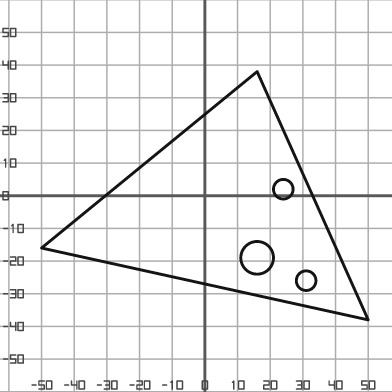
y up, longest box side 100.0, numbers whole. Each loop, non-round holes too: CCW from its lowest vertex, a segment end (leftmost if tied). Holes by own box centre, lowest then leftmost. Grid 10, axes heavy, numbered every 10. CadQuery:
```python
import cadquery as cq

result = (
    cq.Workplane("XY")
    .moveTo(50.0, -38.0)
    .lineTo(16.0, 38.0)
    .lineTo(-50.0, -16.0)
    .close()
    .moveTo(31.0, -26.0)
    .circle(3.0)
    .moveTo(16.0, -19.0)
    .circle(5.0)
    .moveTo(24.0, 2.0)
    .circle(3.0)
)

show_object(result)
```